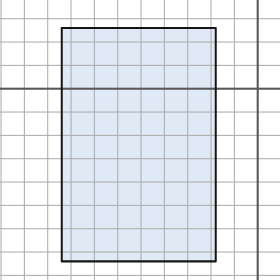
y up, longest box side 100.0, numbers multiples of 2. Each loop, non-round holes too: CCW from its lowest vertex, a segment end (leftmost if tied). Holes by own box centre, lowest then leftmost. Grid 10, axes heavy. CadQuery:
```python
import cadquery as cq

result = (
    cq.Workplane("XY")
    .moveTo(-84.0, -74.0)
    .lineTo(-18.0, -74.0)
    .lineTo(-18.0, 26.0)
    .lineTo(-84.0, 26.0)
    .close()
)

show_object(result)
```